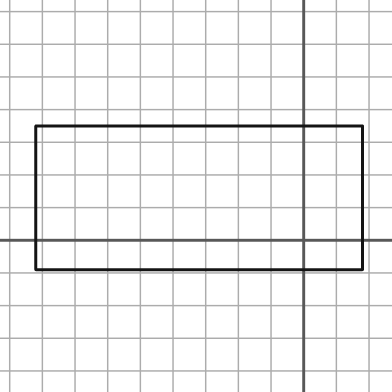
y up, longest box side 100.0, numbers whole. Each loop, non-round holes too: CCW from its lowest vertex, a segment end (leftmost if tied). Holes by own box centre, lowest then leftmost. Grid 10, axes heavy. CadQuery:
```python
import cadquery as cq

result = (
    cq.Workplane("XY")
    .moveTo(-82.0, -9.0)
    .lineTo(18.0, -9.0)
    .lineTo(18.0, 35.0)
    .lineTo(-82.0, 35.0)
    .close()
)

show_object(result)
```